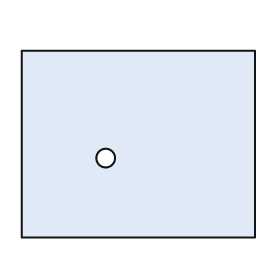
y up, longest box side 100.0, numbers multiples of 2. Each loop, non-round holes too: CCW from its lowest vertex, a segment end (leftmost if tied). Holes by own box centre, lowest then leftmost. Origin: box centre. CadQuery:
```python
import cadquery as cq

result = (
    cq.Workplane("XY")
    .moveTo(-50.0, -40.0)
    .lineTo(50.0, -40.0)
    .lineTo(50.0, 40.0)
    .lineTo(-50.0, 40.0)
    .close()
    .moveTo(-14.0, -6.0)
    .circle(4.0)
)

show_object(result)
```